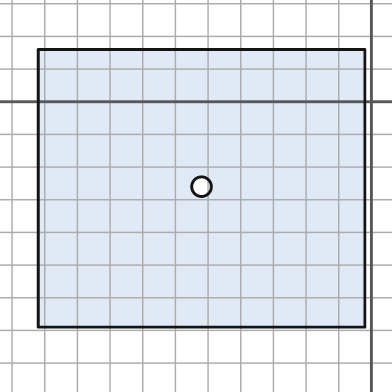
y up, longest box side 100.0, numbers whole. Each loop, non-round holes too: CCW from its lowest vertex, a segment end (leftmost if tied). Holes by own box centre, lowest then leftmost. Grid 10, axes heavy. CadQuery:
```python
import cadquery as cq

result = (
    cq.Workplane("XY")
    .moveTo(-102.0, -69.0)
    .lineTo(-2.0, -69.0)
    .lineTo(-2.0, 16.0)
    .lineTo(-102.0, 16.0)
    .close()
    .moveTo(-52.0, -26.0)
    .circle(3.0)
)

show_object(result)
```